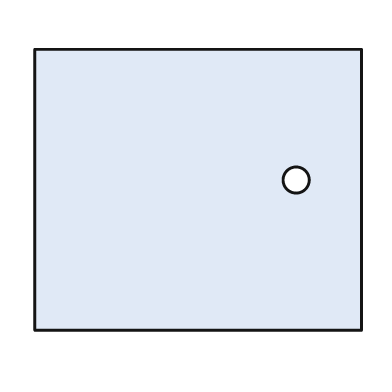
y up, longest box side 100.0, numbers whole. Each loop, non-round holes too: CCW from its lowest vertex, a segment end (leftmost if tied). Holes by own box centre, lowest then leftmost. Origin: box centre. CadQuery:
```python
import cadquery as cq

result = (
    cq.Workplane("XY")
    .moveTo(-50.0, -43.0)
    .lineTo(50.0, -43.0)
    .lineTo(50.0, 43.0)
    .lineTo(-50.0, 43.0)
    .close()
    .moveTo(30.0, 3.0)
    .circle(4.0)
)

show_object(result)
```